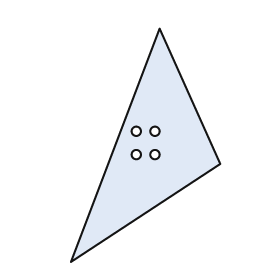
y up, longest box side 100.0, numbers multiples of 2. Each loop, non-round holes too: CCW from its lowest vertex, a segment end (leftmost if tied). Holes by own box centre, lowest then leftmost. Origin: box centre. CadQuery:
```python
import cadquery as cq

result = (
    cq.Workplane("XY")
    .moveTo(-32.0, -50.0)
    .lineTo(32.0, -8.0)
    .lineTo(6.0, 50.0)
    .close()
    .moveTo(-4.0, -4.0)
    .circle(2.0)
    .moveTo(4.0, -4.0)
    .circle(2.0)
    .moveTo(-4.0, 6.0)
    .circle(2.0)
    .moveTo(4.0, 6.0)
    .circle(2.0)
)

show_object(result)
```